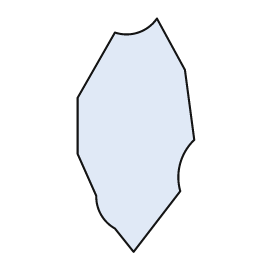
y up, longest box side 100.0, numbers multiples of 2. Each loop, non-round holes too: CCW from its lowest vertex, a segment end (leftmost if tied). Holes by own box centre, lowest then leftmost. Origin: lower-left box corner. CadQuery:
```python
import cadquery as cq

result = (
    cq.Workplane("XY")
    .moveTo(24.0, 0.0)
    .lineTo(44.0, 26.0)
    .threePointArc((44.0, 38.0), (50.0, 48.0))
    .lineTo(46.0, 78.0)
    .lineTo(34.0, 100.0)
    .threePointArc((26.0, 94.0), (16.0, 94.0))
    .lineTo(0.0, 66.0)
    .lineTo(0.0, 42.0)
    .lineTo(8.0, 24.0)
    .threePointArc((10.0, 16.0), (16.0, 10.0))
    .close()
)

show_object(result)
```